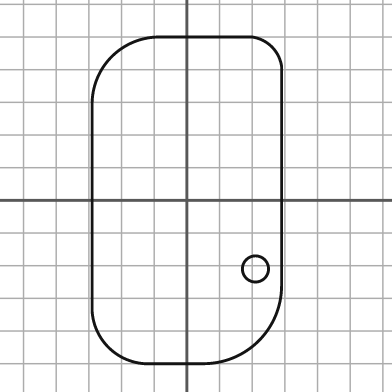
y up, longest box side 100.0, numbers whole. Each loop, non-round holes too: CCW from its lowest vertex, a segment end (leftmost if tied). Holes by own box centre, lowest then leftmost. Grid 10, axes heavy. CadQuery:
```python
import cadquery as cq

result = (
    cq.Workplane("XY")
    .moveTo(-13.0, -50.0)
    .lineTo(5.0, -50.0)
    .threePointArc((22.0, -43.0), (29.0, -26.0))
    .lineTo(29.0, 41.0)
    .threePointArc((26.0, 47.0), (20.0, 50.0))
    .lineTo(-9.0, 50.0)
    .threePointArc((-23.0, 44.0), (-29.0, 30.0))
    .lineTo(-29.0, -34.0)
    .threePointArc((-24.0, -45.0), (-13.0, -50.0))
    .close()
    .moveTo(21.0, -21.0)
    .circle(4.0)
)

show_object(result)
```